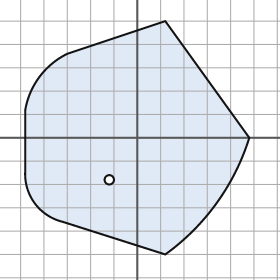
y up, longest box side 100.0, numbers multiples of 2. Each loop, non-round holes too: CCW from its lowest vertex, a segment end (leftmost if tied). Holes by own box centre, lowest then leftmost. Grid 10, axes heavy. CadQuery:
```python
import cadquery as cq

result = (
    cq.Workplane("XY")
    .moveTo(12.0, -50.0)
    .threePointArc((34.0, -28.0), (48.0, 0.0))
    .lineTo(12.0, 50.0)
    .lineTo(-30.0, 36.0)
    .threePointArc((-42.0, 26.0), (-48.0, 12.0))
    .lineTo(-48.0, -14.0)
    .threePointArc((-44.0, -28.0), (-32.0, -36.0))
    .close()
    .moveTo(-12.0, -18.0)
    .circle(2.0)
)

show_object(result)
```